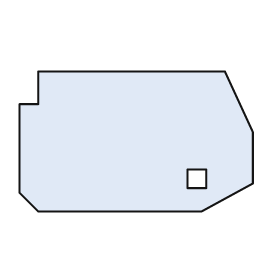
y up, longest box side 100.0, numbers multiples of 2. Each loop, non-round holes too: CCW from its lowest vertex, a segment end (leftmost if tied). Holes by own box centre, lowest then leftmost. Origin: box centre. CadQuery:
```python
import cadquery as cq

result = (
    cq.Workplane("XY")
    .moveTo(-42.0, -30.0)
    .lineTo(28.0, -30.0)
    .lineTo(50.0, -18.0)
    .lineTo(50.0, 4.0)
    .lineTo(38.0, 30.0)
    .lineTo(-42.0, 30.0)
    .lineTo(-42.0, 16.0)
    .lineTo(-50.0, 16.0)
    .lineTo(-50.0, -22.0)
    .close()
    .moveTo(22.0, -20.0)
    .lineTo(30.0, -20.0)
    .lineTo(30.0, -12.0)
    .lineTo(22.0, -12.0)
    .close()
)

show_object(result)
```